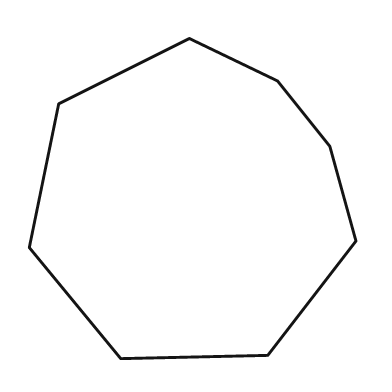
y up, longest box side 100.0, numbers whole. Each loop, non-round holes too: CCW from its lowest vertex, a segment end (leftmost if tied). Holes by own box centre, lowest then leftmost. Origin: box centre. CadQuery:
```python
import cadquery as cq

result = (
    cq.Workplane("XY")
    .moveTo(-22.0, -49.0)
    .lineTo(23.0, -48.0)
    .lineTo(50.0, -13.0)
    .lineTo(42.0, 16.0)
    .lineTo(26.0, 36.0)
    .lineTo(-1.0, 49.0)
    .lineTo(-41.0, 29.0)
    .lineTo(-50.0, -15.0)
    .close()
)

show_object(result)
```